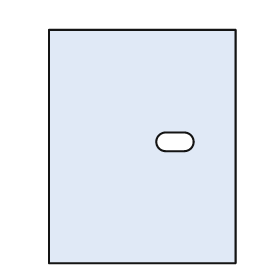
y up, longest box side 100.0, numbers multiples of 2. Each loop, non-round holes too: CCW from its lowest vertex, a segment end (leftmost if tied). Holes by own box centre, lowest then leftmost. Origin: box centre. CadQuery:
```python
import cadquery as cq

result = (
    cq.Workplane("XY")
    .moveTo(-40.0, -50.0)
    .lineTo(40.0, -50.0)
    .lineTo(40.0, 50.0)
    .lineTo(-40.0, 50.0)
    .close()
    .moveTo(10.0, -2.0)
    .lineTo(18.0, -2.0)
    .threePointArc((22.0, 2.0), (18.0, 6.0))
    .lineTo(10.0, 6.0)
    .threePointArc((6.0, 2.0), (10.0, -2.0))
    .close()
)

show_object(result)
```